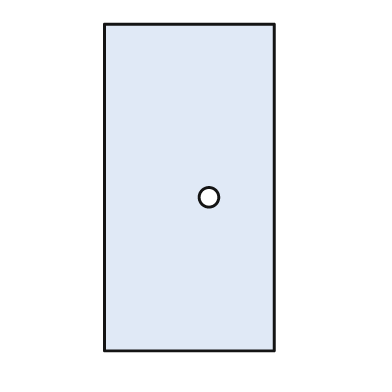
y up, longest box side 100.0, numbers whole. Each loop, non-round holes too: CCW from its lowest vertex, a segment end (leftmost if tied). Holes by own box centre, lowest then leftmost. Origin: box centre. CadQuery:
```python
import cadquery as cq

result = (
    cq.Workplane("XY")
    .moveTo(-26.0, -50.0)
    .lineTo(26.0, -50.0)
    .lineTo(26.0, 50.0)
    .lineTo(-26.0, 50.0)
    .close()
    .moveTo(6.0, -3.0)
    .circle(3.0)
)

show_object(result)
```